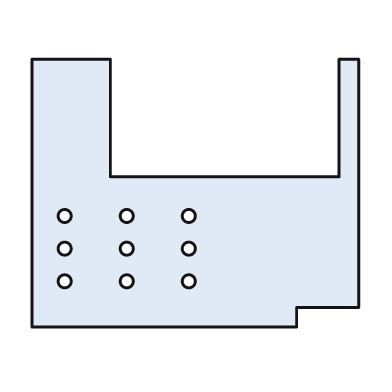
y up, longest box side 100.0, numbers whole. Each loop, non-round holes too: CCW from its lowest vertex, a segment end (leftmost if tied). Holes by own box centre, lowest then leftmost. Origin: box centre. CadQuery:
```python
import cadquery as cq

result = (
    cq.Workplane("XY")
    .moveTo(-50.0, -41.0)
    .lineTo(31.0, -41.0)
    .lineTo(31.0, -35.0)
    .lineTo(50.0, -35.0)
    .lineTo(50.0, 41.0)
    .lineTo(44.0, 41.0)
    .lineTo(44.0, 5.0)
    .lineTo(-26.0, 5.0)
    .lineTo(-26.0, 41.0)
    .lineTo(-50.0, 41.0)
    .close()
    .moveTo(-40.0, -27.0)
    .circle(2.0)
    .moveTo(-21.0, -27.0)
    .circle(2.0)
    .moveTo(-2.0, -27.0)
    .circle(2.0)
    .moveTo(-40.0, -17.0)
    .circle(2.0)
    .moveTo(-21.0, -17.0)
    .circle(2.0)
    .moveTo(-2.0, -17.0)
    .circle(2.0)
    .moveTo(-40.0, -7.0)
    .circle(2.0)
    .moveTo(-21.0, -7.0)
    .circle(2.0)
    .moveTo(-2.0, -7.0)
    .circle(2.0)
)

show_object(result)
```